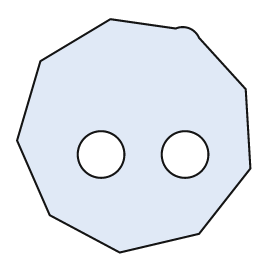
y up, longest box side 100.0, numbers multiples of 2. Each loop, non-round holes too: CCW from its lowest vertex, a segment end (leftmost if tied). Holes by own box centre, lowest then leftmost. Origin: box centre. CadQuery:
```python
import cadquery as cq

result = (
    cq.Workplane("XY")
    .moveTo(-6.0, -50.0)
    .lineTo(28.0, -42.0)
    .lineTo(50.0, -14.0)
    .lineTo(48.0, 20.0)
    .lineTo(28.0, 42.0)
    .threePointArc((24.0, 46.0), (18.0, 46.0))
    .lineTo(-10.0, 50.0)
    .lineTo(-40.0, 32.0)
    .lineTo(-50.0, -2.0)
    .lineTo(-36.0, -34.0)
    .close()
    .moveTo(-14.0, -8.0)
    .circle(10.0)
    .moveTo(22.0, -8.0)
    .circle(10.0)
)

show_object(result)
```